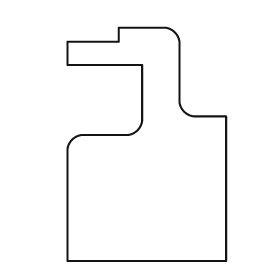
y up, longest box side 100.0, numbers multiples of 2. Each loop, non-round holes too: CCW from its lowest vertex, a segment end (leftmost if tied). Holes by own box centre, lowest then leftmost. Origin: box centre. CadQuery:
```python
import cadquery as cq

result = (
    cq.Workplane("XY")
    .moveTo(-34.0, -50.0)
    .lineTo(34.0, -50.0)
    .lineTo(34.0, 12.0)
    .lineTo(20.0, 12.0)
    .threePointArc((16.0, 14.0), (14.0, 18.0))
    .lineTo(14.0, 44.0)
    .threePointArc((12.0, 48.0), (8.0, 50.0))
    .lineTo(-12.0, 50.0)
    .lineTo(-12.0, 44.0)
    .lineTo(-34.0, 44.0)
    .lineTo(-34.0, 34.0)
    .lineTo(-2.0, 34.0)
    .lineTo(-2.0, 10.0)
    .threePointArc((-4.0, 6.0), (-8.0, 4.0))
    .lineTo(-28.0, 4.0)
    .threePointArc((-32.0, 2.0), (-34.0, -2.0))
    .close()
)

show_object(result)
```